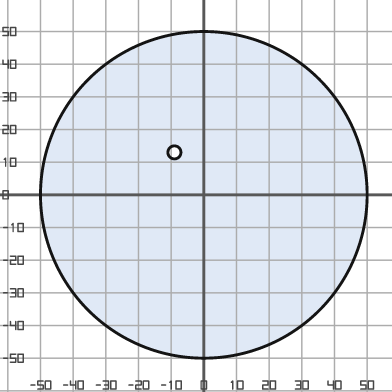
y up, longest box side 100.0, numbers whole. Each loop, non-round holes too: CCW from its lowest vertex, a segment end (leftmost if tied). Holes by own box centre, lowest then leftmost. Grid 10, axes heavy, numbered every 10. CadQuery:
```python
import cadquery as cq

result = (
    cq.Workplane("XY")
    .moveTo(0.0, 0.0)
    .circle(50.0)
    .moveTo(-9.0, 13.0)
    .circle(2.0)
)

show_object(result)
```